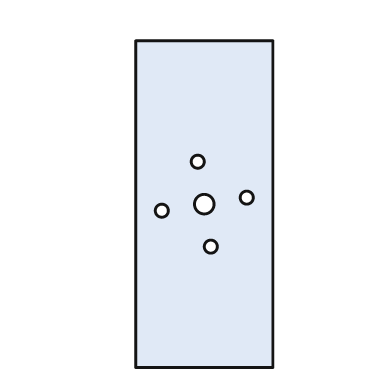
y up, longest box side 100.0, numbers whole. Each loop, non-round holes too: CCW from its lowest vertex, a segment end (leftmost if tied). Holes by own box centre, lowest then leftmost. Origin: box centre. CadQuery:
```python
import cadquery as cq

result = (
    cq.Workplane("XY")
    .moveTo(-21.0, -50.0)
    .lineTo(21.0, -50.0)
    .lineTo(21.0, 50.0)
    .lineTo(-21.0, 50.0)
    .close()
    .moveTo(2.0, -13.0)
    .circle(2.0)
    .moveTo(-13.0, -2.0)
    .circle(2.0)
    .moveTo(0.0, 0.0)
    .circle(3.0)
    .moveTo(13.0, 2.0)
    .circle(2.0)
    .moveTo(-2.0, 13.0)
    .circle(2.0)
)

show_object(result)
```